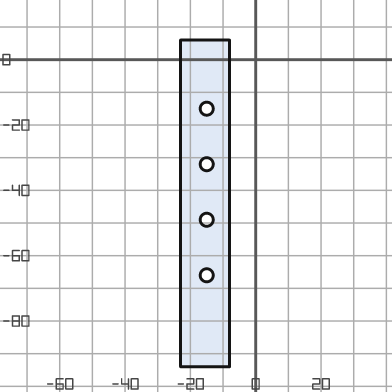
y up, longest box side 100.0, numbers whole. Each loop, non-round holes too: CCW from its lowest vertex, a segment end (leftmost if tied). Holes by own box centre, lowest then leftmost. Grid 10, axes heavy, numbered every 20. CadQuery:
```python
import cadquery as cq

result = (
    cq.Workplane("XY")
    .moveTo(-23.0, -94.0)
    .lineTo(-8.0, -94.0)
    .lineTo(-8.0, 6.0)
    .lineTo(-23.0, 6.0)
    .close()
    .moveTo(-15.0, -66.0)
    .circle(2.0)
    .moveTo(-15.0, -49.0)
    .circle(2.0)
    .moveTo(-15.0, -32.0)
    .circle(2.0)
    .moveTo(-15.0, -15.0)
    .circle(2.0)
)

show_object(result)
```